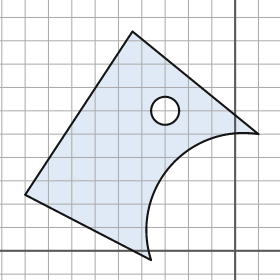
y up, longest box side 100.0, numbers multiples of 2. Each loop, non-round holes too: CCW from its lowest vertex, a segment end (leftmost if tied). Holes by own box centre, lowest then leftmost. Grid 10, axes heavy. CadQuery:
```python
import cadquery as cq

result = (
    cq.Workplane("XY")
    .moveTo(-36.0, -4.0)
    .threePointArc((-28.0, 36.0), (10.0, 50.0))
    .lineTo(-44.0, 94.0)
    .lineTo(-90.0, 24.0)
    .close()
    .moveTo(-30.0, 60.0)
    .circle(6.0)
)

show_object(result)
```